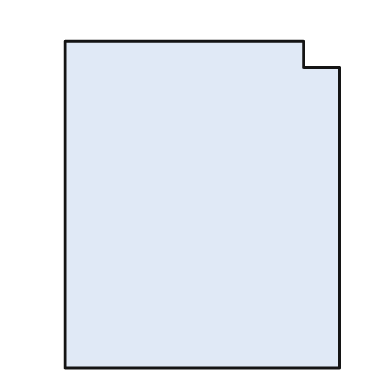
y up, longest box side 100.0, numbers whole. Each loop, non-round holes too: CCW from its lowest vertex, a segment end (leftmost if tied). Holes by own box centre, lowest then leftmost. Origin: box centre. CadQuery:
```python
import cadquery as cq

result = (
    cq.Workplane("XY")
    .moveTo(-42.0, -50.0)
    .lineTo(42.0, -50.0)
    .lineTo(42.0, 42.0)
    .lineTo(31.0, 42.0)
    .lineTo(31.0, 50.0)
    .lineTo(-42.0, 50.0)
    .close()
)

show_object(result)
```